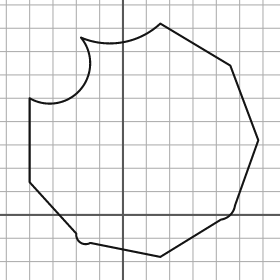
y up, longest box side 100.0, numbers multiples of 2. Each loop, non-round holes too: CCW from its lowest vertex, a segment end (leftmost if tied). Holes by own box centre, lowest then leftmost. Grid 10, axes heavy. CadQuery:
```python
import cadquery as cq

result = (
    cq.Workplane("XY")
    .moveTo(16.0, -18.0)
    .lineTo(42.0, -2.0)
    .threePointArc((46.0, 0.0), (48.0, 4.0))
    .lineTo(58.0, 32.0)
    .lineTo(46.0, 64.0)
    .lineTo(16.0, 82.0)
    .threePointArc((0.0, 74.0), (-18.0, 76.0))
    .threePointArc((-18.0, 54.0), (-40.0, 50.0))
    .lineTo(-40.0, 14.0)
    .lineTo(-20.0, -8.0)
    .threePointArc((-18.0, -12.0), (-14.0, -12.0))
    .close()
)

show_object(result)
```